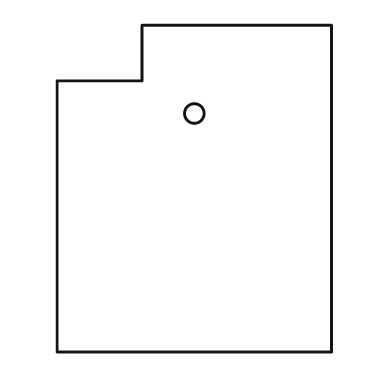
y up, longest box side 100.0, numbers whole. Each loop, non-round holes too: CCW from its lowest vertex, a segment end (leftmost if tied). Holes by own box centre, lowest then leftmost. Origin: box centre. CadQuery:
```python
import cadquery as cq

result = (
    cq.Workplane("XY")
    .moveTo(-42.0, -50.0)
    .lineTo(42.0, -50.0)
    .lineTo(42.0, 50.0)
    .lineTo(-16.0, 50.0)
    .lineTo(-16.0, 33.0)
    .lineTo(-42.0, 33.0)
    .close()
    .moveTo(0.0, 23.0)
    .circle(3.0)
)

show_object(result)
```